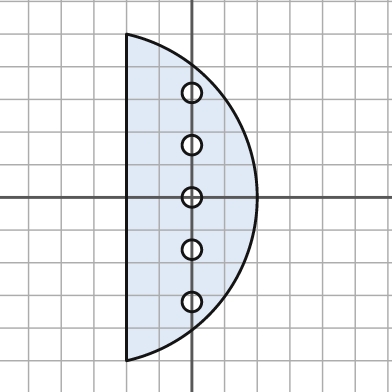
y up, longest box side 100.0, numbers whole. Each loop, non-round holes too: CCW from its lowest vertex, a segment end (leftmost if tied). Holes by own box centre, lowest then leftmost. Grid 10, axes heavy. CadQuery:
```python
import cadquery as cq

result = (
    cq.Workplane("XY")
    .moveTo(-20.0, -50.0)
    .threePointArc((20.0, 0.0), (-20.0, 50.0))
    .close()
    .moveTo(0.0, -32.0)
    .circle(3.0)
    .moveTo(0.0, -16.0)
    .circle(3.0)
    .moveTo(0.0, 0.0)
    .circle(3.0)
    .moveTo(0.0, 16.0)
    .circle(3.0)
    .moveTo(0.0, 32.0)
    .circle(3.0)
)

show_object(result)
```